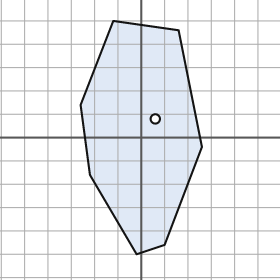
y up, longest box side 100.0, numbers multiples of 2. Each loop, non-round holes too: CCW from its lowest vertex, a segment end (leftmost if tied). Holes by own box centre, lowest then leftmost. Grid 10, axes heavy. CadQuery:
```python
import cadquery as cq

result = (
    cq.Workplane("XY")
    .moveTo(-2.0, -50.0)
    .lineTo(10.0, -46.0)
    .lineTo(26.0, -4.0)
    .lineTo(16.0, 46.0)
    .lineTo(-12.0, 50.0)
    .lineTo(-26.0, 14.0)
    .lineTo(-22.0, -16.0)
    .close()
    .moveTo(6.0, 8.0)
    .circle(2.0)
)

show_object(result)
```